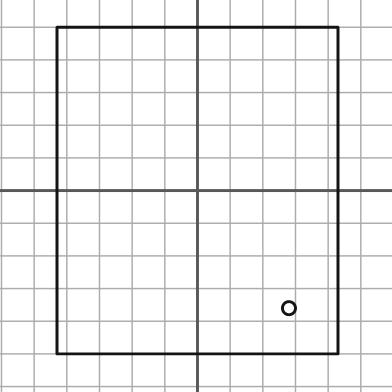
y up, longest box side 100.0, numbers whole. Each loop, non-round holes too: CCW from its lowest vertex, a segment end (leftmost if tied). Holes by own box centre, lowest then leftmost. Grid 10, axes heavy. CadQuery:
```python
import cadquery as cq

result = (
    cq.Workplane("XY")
    .moveTo(-43.0, -50.0)
    .lineTo(43.0, -50.0)
    .lineTo(43.0, 50.0)
    .lineTo(-43.0, 50.0)
    .close()
    .moveTo(28.0, -36.0)
    .circle(2.0)
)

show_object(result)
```